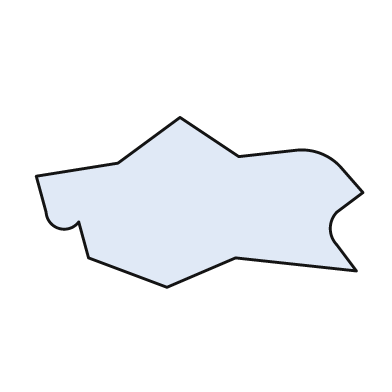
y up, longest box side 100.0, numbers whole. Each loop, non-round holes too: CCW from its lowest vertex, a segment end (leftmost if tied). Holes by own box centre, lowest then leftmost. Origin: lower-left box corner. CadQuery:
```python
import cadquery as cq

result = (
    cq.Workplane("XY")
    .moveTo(40.0, 0.0)
    .lineTo(61.0, 9.0)
    .lineTo(98.0, 5.0)
    .lineTo(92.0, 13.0)
    .threePointArc((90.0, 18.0), (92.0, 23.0))
    .lineTo(100.0, 29.0)
    .lineTo(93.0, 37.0)
    .threePointArc((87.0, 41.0), (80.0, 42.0))
    .lineTo(62.0, 40.0)
    .lineTo(44.0, 52.0)
    .lineTo(25.0, 38.0)
    .lineTo(0.0, 34.0)
    .lineTo(3.0, 23.0)
    .threePointArc((7.0, 18.0), (13.0, 20.0))
    .lineTo(16.0, 9.0)
    .close()
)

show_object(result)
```